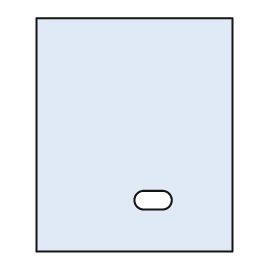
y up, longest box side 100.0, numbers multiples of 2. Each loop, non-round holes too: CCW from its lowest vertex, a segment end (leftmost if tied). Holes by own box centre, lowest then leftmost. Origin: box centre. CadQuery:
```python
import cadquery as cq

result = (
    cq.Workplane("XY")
    .moveTo(-42.0, -50.0)
    .lineTo(42.0, -50.0)
    .lineTo(42.0, 50.0)
    .lineTo(-42.0, 50.0)
    .close()
    .moveTo(4.0, -32.0)
    .lineTo(12.0, -32.0)
    .threePointArc((16.0, -28.0), (12.0, -24.0))
    .lineTo(4.0, -24.0)
    .threePointArc((0.0, -28.0), (4.0, -32.0))
    .close()
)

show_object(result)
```